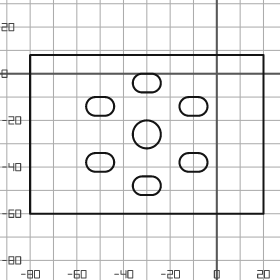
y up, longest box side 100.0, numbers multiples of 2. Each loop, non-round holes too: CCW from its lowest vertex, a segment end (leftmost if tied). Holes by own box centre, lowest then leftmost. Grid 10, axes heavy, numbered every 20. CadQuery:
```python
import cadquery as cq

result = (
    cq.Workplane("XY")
    .moveTo(-80.0, -60.0)
    .lineTo(20.0, -60.0)
    .lineTo(20.0, 8.0)
    .lineTo(-80.0, 8.0)
    .close()
    .moveTo(-32.0, -52.0)
    .lineTo(-28.0, -52.0)
    .threePointArc((-24.0, -48.0), (-28.0, -44.0))
    .lineTo(-32.0, -44.0)
    .threePointArc((-36.0, -48.0), (-32.0, -52.0))
    .close()
    .moveTo(-52.0, -42.0)
    .lineTo(-48.0, -42.0)
    .threePointArc((-44.0, -38.0), (-48.0, -34.0))
    .lineTo(-52.0, -34.0)
    .threePointArc((-56.0, -38.0), (-52.0, -42.0))
    .close()
    .moveTo(-12.0, -42.0)
    .lineTo(-8.0, -42.0)
    .threePointArc((-4.0, -38.0), (-8.0, -34.0))
    .lineTo(-12.0, -34.0)
    .threePointArc((-16.0, -38.0), (-12.0, -42.0))
    .close()
    .moveTo(-30.0, -26.0)
    .circle(6.0)
    .moveTo(-52.0, -18.0)
    .lineTo(-48.0, -18.0)
    .threePointArc((-44.0, -14.0), (-48.0, -10.0))
    .lineTo(-52.0, -10.0)
    .threePointArc((-56.0, -14.0), (-52.0, -18.0))
    .close()
    .moveTo(-12.0, -18.0)
    .lineTo(-8.0, -18.0)
    .threePointArc((-4.0, -14.0), (-8.0, -10.0))
    .lineTo(-12.0, -10.0)
    .threePointArc((-16.0, -14.0), (-12.0, -18.0))
    .close()
    .moveTo(-32.0, -8.0)
    .lineTo(-28.0, -8.0)
    .threePointArc((-24.0, -4.0), (-28.0, 0.0))
    .lineTo(-32.0, 0.0)
    .threePointArc((-36.0, -4.0), (-32.0, -8.0))
    .close()
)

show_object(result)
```